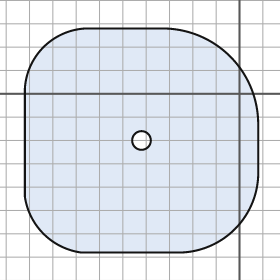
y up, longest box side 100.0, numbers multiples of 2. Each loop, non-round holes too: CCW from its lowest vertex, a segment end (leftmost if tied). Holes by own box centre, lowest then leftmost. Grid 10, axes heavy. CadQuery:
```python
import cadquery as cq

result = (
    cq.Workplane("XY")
    .moveTo(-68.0, -68.0)
    .lineTo(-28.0, -68.0)
    .threePointArc((-2.0, -58.0), (8.0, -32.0))
    .lineTo(8.0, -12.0)
    .threePointArc((-4.0, 16.0), (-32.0, 28.0))
    .lineTo(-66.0, 28.0)
    .threePointArc((-84.0, 20.0), (-92.0, 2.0))
    .lineTo(-92.0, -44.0)
    .threePointArc((-84.0, -60.0), (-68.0, -68.0))
    .close()
    .moveTo(-42.0, -20.0)
    .circle(4.0)
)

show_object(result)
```